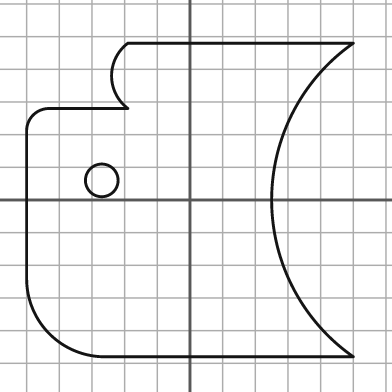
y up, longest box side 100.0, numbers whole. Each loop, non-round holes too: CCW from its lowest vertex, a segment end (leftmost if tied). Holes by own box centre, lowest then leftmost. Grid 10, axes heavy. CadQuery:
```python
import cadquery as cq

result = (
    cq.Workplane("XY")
    .moveTo(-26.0, -48.0)
    .lineTo(50.0, -48.0)
    .threePointArc((25.0, 0.0), (50.0, 48.0))
    .lineTo(-19.0, 48.0)
    .threePointArc((-24.0, 38.0), (-19.0, 28.0))
    .lineTo(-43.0, 28.0)
    .threePointArc((-48.0, 26.0), (-50.0, 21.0))
    .lineTo(-50.0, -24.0)
    .threePointArc((-43.0, -41.0), (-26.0, -48.0))
    .close()
    .moveTo(-27.0, 6.0)
    .circle(5.0)
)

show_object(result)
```